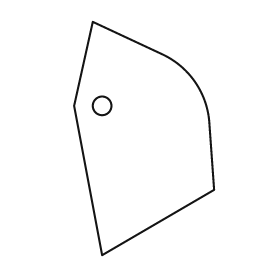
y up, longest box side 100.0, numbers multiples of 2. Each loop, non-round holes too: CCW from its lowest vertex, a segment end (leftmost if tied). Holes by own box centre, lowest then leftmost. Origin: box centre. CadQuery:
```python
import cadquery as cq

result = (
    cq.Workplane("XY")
    .moveTo(-18.0, -50.0)
    .lineTo(30.0, -22.0)
    .lineTo(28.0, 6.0)
    .threePointArc((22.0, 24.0), (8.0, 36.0))
    .lineTo(-22.0, 50.0)
    .lineTo(-30.0, 14.0)
    .close()
    .moveTo(-18.0, 14.0)
    .circle(4.0)
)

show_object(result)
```